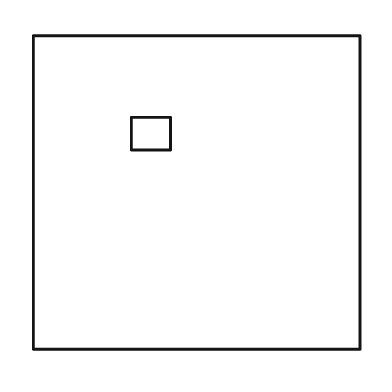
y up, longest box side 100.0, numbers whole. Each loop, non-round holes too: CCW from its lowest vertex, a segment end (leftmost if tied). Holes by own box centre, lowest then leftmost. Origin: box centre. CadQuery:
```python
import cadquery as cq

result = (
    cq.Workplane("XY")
    .moveTo(-50.0, -48.0)
    .lineTo(50.0, -48.0)
    .lineTo(50.0, 48.0)
    .lineTo(-50.0, 48.0)
    .close()
    .moveTo(-20.0, 13.0)
    .lineTo(-8.0, 13.0)
    .lineTo(-8.0, 23.0)
    .lineTo(-20.0, 23.0)
    .close()
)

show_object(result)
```